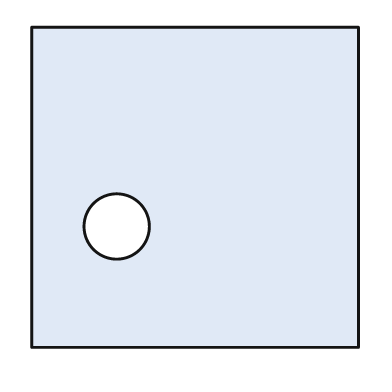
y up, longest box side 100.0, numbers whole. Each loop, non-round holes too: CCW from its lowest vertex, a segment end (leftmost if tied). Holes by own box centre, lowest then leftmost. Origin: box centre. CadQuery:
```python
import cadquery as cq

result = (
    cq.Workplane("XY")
    .moveTo(-50.0, -49.0)
    .lineTo(50.0, -49.0)
    .lineTo(50.0, 49.0)
    .lineTo(-50.0, 49.0)
    .close()
    .moveTo(-24.0, -12.0)
    .circle(10.0)
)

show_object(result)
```